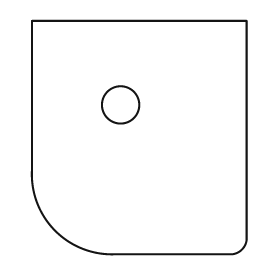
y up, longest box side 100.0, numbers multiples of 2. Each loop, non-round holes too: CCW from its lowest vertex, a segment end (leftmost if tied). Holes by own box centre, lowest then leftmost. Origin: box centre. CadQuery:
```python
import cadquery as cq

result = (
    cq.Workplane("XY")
    .moveTo(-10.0, -50.0)
    .lineTo(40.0, -50.0)
    .threePointArc((44.0, -48.0), (46.0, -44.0))
    .lineTo(46.0, 50.0)
    .lineTo(-46.0, 50.0)
    .lineTo(-46.0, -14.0)
    .threePointArc((-36.0, -40.0), (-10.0, -50.0))
    .close()
    .moveTo(-8.0, 14.0)
    .circle(8.0)
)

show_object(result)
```